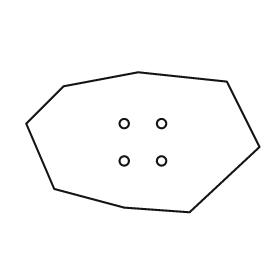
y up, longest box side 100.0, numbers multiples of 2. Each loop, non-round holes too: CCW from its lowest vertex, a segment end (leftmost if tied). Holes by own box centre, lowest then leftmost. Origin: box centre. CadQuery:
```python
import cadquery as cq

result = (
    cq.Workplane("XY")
    .moveTo(20.0, -30.0)
    .lineTo(50.0, -2.0)
    .lineTo(36.0, 26.0)
    .lineTo(-2.0, 30.0)
    .lineTo(-34.0, 24.0)
    .lineTo(-50.0, 8.0)
    .lineTo(-38.0, -20.0)
    .lineTo(-8.0, -28.0)
    .close()
    .moveTo(-8.0, -8.0)
    .circle(2.0)
    .moveTo(8.0, -8.0)
    .circle(2.0)
    .moveTo(-8.0, 8.0)
    .circle(2.0)
    .moveTo(8.0, 8.0)
    .circle(2.0)
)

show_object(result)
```